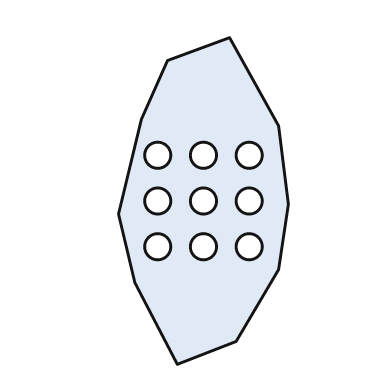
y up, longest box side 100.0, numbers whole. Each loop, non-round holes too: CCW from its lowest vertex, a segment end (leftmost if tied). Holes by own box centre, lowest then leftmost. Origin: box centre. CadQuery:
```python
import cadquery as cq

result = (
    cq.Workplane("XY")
    .moveTo(-8.0, -50.0)
    .lineTo(10.0, -43.0)
    .lineTo(23.0, -21.0)
    .lineTo(26.0, -1.0)
    .lineTo(23.0, 23.0)
    .lineTo(8.0, 50.0)
    .lineTo(-11.0, 43.0)
    .lineTo(-19.0, 25.0)
    .lineTo(-26.0, -4.0)
    .lineTo(-21.0, -25.0)
    .close()
    .moveTo(-14.0, -14.0)
    .circle(4.0)
    .moveTo(0.0, -14.0)
    .circle(4.0)
    .moveTo(14.0, -14.0)
    .circle(4.0)
    .moveTo(-14.0, 0.0)
    .circle(4.0)
    .moveTo(0.0, 0.0)
    .circle(4.0)
    .moveTo(14.0, 0.0)
    .circle(4.0)
    .moveTo(-14.0, 14.0)
    .circle(4.0)
    .moveTo(0.0, 14.0)
    .circle(4.0)
    .moveTo(14.0, 14.0)
    .circle(4.0)
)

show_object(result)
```